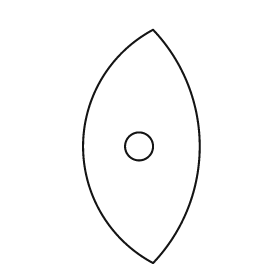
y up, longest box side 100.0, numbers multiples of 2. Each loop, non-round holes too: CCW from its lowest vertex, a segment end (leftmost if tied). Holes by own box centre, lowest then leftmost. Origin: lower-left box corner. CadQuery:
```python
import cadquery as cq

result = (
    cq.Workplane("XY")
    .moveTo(30.0, 0.0)
    .threePointArc((50.0, 50.0), (30.0, 100.0))
    .threePointArc((0.0, 50.0), (30.0, 0.0))
    .close()
    .moveTo(24.0, 50.0)
    .circle(6.0)
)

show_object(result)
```